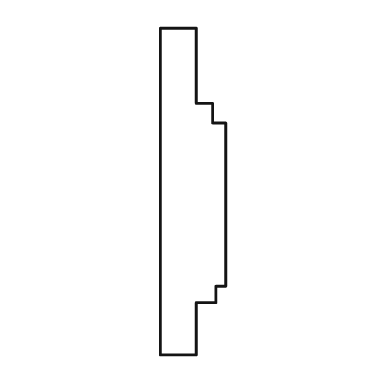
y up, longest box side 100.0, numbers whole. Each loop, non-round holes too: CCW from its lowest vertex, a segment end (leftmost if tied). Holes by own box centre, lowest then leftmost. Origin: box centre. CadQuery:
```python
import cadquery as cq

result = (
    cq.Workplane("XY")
    .moveTo(-10.0, -50.0)
    .lineTo(1.0, -50.0)
    .lineTo(1.0, -34.0)
    .lineTo(7.0, -34.0)
    .lineTo(7.0, -29.0)
    .lineTo(10.0, -29.0)
    .lineTo(10.0, 21.0)
    .lineTo(6.0, 21.0)
    .lineTo(6.0, 27.0)
    .lineTo(1.0, 27.0)
    .lineTo(1.0, 50.0)
    .lineTo(-10.0, 50.0)
    .close()
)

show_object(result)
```